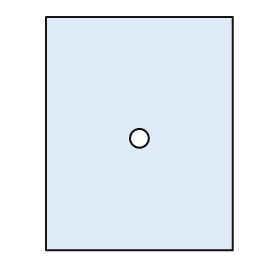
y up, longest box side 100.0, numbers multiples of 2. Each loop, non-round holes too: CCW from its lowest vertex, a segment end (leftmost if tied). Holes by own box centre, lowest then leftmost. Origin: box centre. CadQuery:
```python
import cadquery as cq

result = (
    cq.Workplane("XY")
    .moveTo(-40.0, -50.0)
    .lineTo(40.0, -50.0)
    .lineTo(40.0, 50.0)
    .lineTo(-40.0, 50.0)
    .close()
    .moveTo(0.0, -2.0)
    .circle(4.0)
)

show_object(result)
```